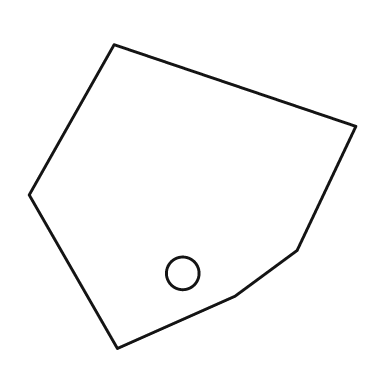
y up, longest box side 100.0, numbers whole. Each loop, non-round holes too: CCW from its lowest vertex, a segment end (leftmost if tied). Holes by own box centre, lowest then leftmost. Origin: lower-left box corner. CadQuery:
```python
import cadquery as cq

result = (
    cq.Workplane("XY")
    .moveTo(27.0, 0.0)
    .lineTo(63.0, 16.0)
    .lineTo(82.0, 30.0)
    .lineTo(100.0, 68.0)
    .lineTo(26.0, 93.0)
    .lineTo(0.0, 47.0)
    .close()
    .moveTo(47.0, 23.0)
    .circle(5.0)
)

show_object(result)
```